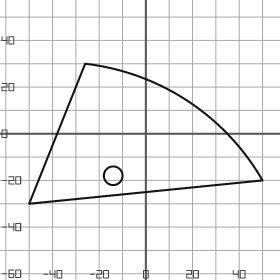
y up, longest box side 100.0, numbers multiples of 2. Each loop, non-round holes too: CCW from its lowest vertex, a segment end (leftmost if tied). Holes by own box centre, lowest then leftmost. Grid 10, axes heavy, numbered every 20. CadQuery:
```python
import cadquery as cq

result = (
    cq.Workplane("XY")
    .moveTo(-50.0, -30.0)
    .lineTo(50.0, -20.0)
    .threePointArc((18.0, 14.0), (-26.0, 30.0))
    .close()
    .moveTo(-14.0, -18.0)
    .circle(4.0)
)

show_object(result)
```